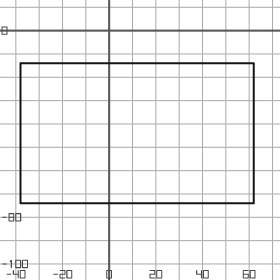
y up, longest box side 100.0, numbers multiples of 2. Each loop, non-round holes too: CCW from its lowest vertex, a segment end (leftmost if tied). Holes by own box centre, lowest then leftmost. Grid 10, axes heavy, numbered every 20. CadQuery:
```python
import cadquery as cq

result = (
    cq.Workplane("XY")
    .moveTo(-38.0, -74.0)
    .lineTo(62.0, -74.0)
    .lineTo(62.0, -14.0)
    .lineTo(-38.0, -14.0)
    .close()
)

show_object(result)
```